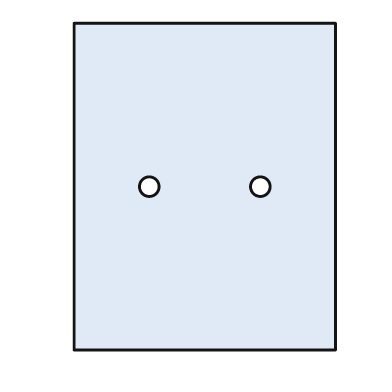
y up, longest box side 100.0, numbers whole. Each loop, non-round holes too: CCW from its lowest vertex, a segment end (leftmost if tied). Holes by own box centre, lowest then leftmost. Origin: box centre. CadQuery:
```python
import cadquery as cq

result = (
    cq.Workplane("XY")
    .moveTo(-40.0, -50.0)
    .lineTo(40.0, -50.0)
    .lineTo(40.0, 50.0)
    .lineTo(-40.0, 50.0)
    .close()
    .moveTo(-17.0, 0.0)
    .circle(3.0)
    .moveTo(17.0, 0.0)
    .circle(3.0)
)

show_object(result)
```